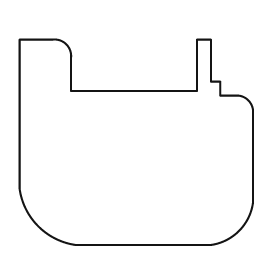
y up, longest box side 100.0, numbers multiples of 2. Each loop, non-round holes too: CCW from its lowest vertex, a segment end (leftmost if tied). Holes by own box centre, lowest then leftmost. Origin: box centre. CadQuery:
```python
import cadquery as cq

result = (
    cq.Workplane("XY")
    .moveTo(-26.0, -44.0)
    .lineTo(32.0, -44.0)
    .threePointArc((44.0, -38.0), (50.0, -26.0))
    .lineTo(50.0, 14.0)
    .threePointArc((48.0, 18.0), (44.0, 20.0))
    .lineTo(36.0, 20.0)
    .lineTo(36.0, 26.0)
    .lineTo(32.0, 26.0)
    .lineTo(32.0, 44.0)
    .lineTo(26.0, 44.0)
    .lineTo(26.0, 22.0)
    .lineTo(-28.0, 22.0)
    .lineTo(-28.0, 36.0)
    .threePointArc((-30.0, 42.0), (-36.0, 44.0))
    .lineTo(-50.0, 44.0)
    .lineTo(-50.0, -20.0)
    .threePointArc((-42.0, -36.0), (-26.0, -44.0))
    .close()
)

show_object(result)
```